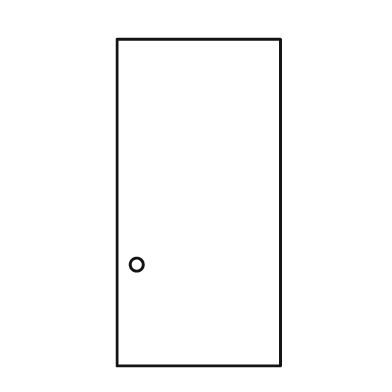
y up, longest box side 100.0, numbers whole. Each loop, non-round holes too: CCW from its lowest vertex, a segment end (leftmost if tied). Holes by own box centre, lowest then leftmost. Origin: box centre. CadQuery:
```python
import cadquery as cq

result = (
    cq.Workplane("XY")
    .moveTo(-25.0, -50.0)
    .lineTo(25.0, -50.0)
    .lineTo(25.0, 50.0)
    .lineTo(-25.0, 50.0)
    .close()
    .moveTo(-19.0, -19.0)
    .circle(2.0)
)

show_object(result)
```